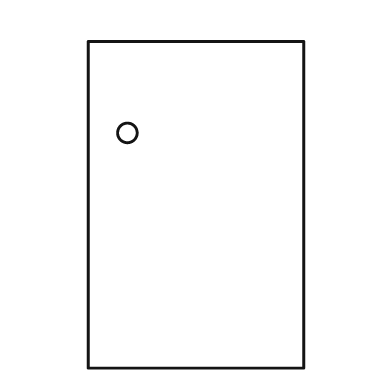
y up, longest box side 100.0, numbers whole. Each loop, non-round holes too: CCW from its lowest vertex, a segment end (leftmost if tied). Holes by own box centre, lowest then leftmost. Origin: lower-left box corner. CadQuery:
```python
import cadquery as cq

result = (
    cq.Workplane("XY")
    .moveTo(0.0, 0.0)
    .lineTo(66.0, 0.0)
    .lineTo(66.0, 100.0)
    .lineTo(0.0, 100.0)
    .close()
    .moveTo(12.0, 72.0)
    .circle(3.0)
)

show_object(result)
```